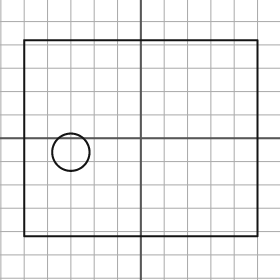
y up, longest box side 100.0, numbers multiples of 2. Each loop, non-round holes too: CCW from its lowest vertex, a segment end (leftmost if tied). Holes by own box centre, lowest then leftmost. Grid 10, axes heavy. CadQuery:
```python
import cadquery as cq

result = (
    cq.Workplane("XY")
    .moveTo(-50.0, -42.0)
    .lineTo(50.0, -42.0)
    .lineTo(50.0, 42.0)
    .lineTo(-50.0, 42.0)
    .close()
    .moveTo(-30.0, -6.0)
    .circle(8.0)
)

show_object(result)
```